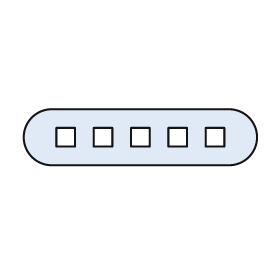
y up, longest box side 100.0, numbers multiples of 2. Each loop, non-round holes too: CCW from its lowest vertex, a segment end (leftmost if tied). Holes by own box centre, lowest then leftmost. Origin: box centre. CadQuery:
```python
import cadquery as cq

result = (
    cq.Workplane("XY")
    .moveTo(-38.0, -12.0)
    .lineTo(38.0, -12.0)
    .threePointArc((50.0, 0.0), (38.0, 12.0))
    .lineTo(-38.0, 12.0)
    .threePointArc((-50.0, 0.0), (-38.0, -12.0))
    .close()
    .moveTo(-36.0, -4.0)
    .lineTo(-28.0, -4.0)
    .lineTo(-28.0, 4.0)
    .lineTo(-36.0, 4.0)
    .close()
    .moveTo(-20.0, -4.0)
    .lineTo(-12.0, -4.0)
    .lineTo(-12.0, 4.0)
    .lineTo(-20.0, 4.0)
    .close()
    .moveTo(-4.0, -4.0)
    .lineTo(4.0, -4.0)
    .lineTo(4.0, 4.0)
    .lineTo(-4.0, 4.0)
    .close()
    .moveTo(12.0, -4.0)
    .lineTo(20.0, -4.0)
    .lineTo(20.0, 4.0)
    .lineTo(12.0, 4.0)
    .close()
    .moveTo(28.0, -4.0)
    .lineTo(36.0, -4.0)
    .lineTo(36.0, 4.0)
    .lineTo(28.0, 4.0)
    .close()
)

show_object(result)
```